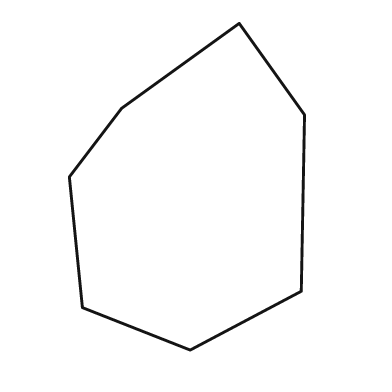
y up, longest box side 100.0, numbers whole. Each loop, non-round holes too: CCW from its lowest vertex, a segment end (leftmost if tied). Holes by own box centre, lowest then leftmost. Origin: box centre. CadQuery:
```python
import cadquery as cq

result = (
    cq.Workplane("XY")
    .moveTo(1.0, -50.0)
    .lineTo(35.0, -32.0)
    .lineTo(36.0, 22.0)
    .lineTo(16.0, 50.0)
    .lineTo(-20.0, 24.0)
    .lineTo(-36.0, 3.0)
    .lineTo(-32.0, -37.0)
    .close()
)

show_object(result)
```